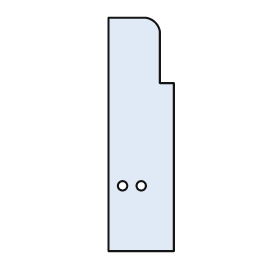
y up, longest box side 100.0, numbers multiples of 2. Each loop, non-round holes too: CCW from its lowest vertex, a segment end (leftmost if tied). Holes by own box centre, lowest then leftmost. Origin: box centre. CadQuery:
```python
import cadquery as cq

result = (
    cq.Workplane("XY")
    .moveTo(-14.0, -50.0)
    .lineTo(14.0, -50.0)
    .lineTo(14.0, 22.0)
    .lineTo(8.0, 22.0)
    .lineTo(8.0, 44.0)
    .threePointArc((6.0, 48.0), (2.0, 50.0))
    .lineTo(-14.0, 50.0)
    .close()
    .moveTo(-8.0, -22.0)
    .circle(2.0)
    .moveTo(0.0, -22.0)
    .circle(2.0)
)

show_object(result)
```